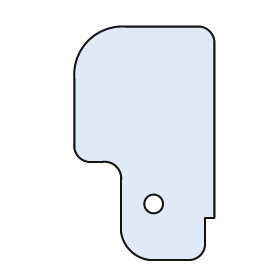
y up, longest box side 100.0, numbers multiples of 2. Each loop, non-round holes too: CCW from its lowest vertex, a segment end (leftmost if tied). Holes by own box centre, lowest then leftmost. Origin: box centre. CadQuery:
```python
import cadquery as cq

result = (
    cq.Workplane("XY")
    .moveTo(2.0, -50.0)
    .lineTo(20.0, -50.0)
    .threePointArc((24.0, -48.0), (26.0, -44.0))
    .lineTo(26.0, -32.0)
    .lineTo(30.0, -32.0)
    .lineTo(30.0, 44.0)
    .threePointArc((28.0, 48.0), (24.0, 50.0))
    .lineTo(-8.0, 50.0)
    .threePointArc((-24.0, 44.0), (-30.0, 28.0))
    .lineTo(-30.0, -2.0)
    .threePointArc((-28.0, -6.0), (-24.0, -8.0))
    .lineTo(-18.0, -8.0)
    .threePointArc((-12.0, -10.0), (-10.0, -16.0))
    .lineTo(-10.0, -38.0)
    .threePointArc((-6.0, -46.0), (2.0, -50.0))
    .close()
    .moveTo(4.0, -26.0)
    .circle(4.0)
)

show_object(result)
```